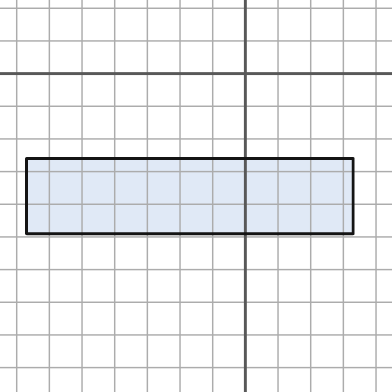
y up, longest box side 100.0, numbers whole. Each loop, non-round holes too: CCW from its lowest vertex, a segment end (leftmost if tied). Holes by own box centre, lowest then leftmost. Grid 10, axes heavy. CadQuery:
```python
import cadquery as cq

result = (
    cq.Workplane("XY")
    .moveTo(-67.0, -49.0)
    .lineTo(33.0, -49.0)
    .lineTo(33.0, -26.0)
    .lineTo(-67.0, -26.0)
    .close()
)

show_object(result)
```